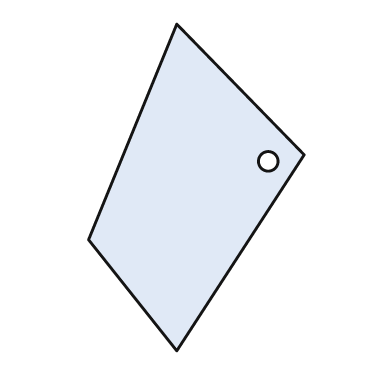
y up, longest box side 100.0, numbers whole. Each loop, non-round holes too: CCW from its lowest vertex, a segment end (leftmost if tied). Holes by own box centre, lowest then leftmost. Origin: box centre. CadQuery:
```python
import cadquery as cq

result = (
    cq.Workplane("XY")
    .moveTo(-6.0, -50.0)
    .lineTo(33.0, 10.0)
    .lineTo(-6.0, 50.0)
    .lineTo(-33.0, -16.0)
    .close()
    .moveTo(22.0, 8.0)
    .circle(3.0)
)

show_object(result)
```